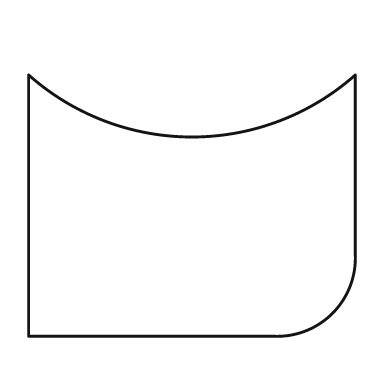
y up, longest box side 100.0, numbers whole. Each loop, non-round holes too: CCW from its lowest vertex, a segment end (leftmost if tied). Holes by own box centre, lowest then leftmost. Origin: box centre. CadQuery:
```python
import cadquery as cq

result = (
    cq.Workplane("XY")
    .moveTo(-50.0, -40.0)
    .lineTo(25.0, -40.0)
    .threePointArc((43.0, -33.0), (50.0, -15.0))
    .lineTo(50.0, 40.0)
    .threePointArc((0.0, 21.0), (-50.0, 40.0))
    .close()
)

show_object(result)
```